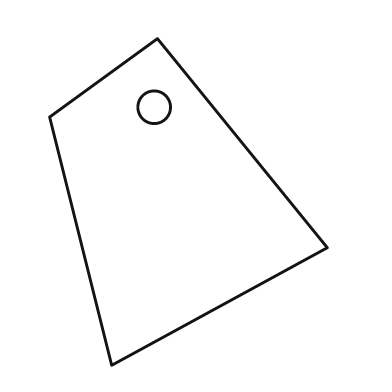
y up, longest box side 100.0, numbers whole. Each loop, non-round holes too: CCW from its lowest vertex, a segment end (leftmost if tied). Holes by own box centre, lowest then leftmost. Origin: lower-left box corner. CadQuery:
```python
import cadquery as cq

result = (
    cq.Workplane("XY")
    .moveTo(19.0, 0.0)
    .lineTo(85.0, 36.0)
    .lineTo(33.0, 100.0)
    .lineTo(0.0, 76.0)
    .close()
    .moveTo(32.0, 79.0)
    .circle(5.0)
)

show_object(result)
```